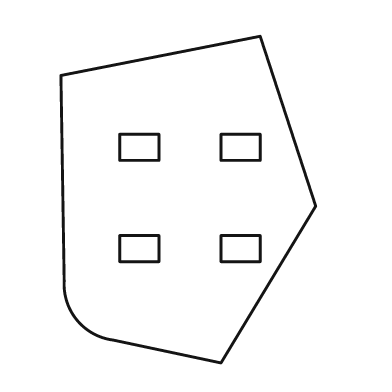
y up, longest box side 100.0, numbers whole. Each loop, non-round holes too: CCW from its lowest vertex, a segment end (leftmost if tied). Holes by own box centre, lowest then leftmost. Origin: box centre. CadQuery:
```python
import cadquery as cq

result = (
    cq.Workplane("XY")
    .moveTo(10.0, -50.0)
    .lineTo(39.0, -2.0)
    .lineTo(22.0, 50.0)
    .lineTo(-39.0, 38.0)
    .lineTo(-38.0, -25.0)
    .threePointArc((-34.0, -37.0), (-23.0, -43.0))
    .close()
    .moveTo(-21.0, -19.0)
    .lineTo(-9.0, -19.0)
    .lineTo(-9.0, -11.0)
    .lineTo(-21.0, -11.0)
    .close()
    .moveTo(10.0, -19.0)
    .lineTo(22.0, -19.0)
    .lineTo(22.0, -11.0)
    .lineTo(10.0, -11.0)
    .close()
    .moveTo(-21.0, 12.0)
    .lineTo(-9.0, 12.0)
    .lineTo(-9.0, 20.0)
    .lineTo(-21.0, 20.0)
    .close()
    .moveTo(10.0, 12.0)
    .lineTo(22.0, 12.0)
    .lineTo(22.0, 20.0)
    .lineTo(10.0, 20.0)
    .close()
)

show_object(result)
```